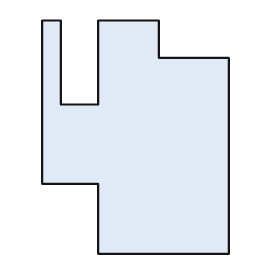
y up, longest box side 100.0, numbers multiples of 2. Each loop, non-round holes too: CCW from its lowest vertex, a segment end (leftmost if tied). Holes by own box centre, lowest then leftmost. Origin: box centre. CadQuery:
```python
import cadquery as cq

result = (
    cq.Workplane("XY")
    .moveTo(-16.0, -50.0)
    .lineTo(40.0, -50.0)
    .lineTo(40.0, 34.0)
    .lineTo(10.0, 34.0)
    .lineTo(10.0, 50.0)
    .lineTo(-16.0, 50.0)
    .lineTo(-16.0, 14.0)
    .lineTo(-32.0, 14.0)
    .lineTo(-32.0, 50.0)
    .lineTo(-40.0, 50.0)
    .lineTo(-40.0, -20.0)
    .lineTo(-16.0, -20.0)
    .close()
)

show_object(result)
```